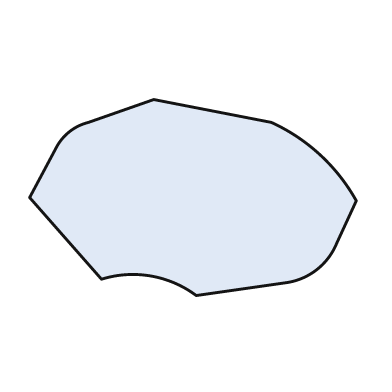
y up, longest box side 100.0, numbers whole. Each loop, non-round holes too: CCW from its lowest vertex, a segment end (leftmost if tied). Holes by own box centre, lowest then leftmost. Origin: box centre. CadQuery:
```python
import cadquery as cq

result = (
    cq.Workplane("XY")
    .moveTo(1.0, -30.0)
    .lineTo(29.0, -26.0)
    .threePointArc((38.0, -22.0), (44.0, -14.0))
    .lineTo(50.0, -1.0)
    .threePointArc((39.0, 13.0), (24.0, 23.0))
    .lineTo(-12.0, 30.0)
    .lineTo(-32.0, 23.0)
    .threePointArc((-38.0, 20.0), (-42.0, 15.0))
    .lineTo(-50.0, 0.0)
    .lineTo(-28.0, -25.0)
    .threePointArc((-13.0, -24.0), (1.0, -30.0))
    .close()
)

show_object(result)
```